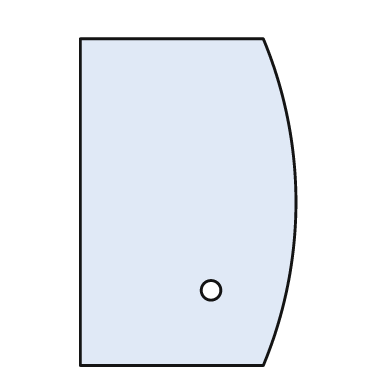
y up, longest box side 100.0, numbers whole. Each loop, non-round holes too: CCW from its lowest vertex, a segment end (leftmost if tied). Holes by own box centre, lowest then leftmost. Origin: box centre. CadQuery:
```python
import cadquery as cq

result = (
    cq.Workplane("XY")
    .moveTo(-33.0, -50.0)
    .lineTo(23.0, -50.0)
    .threePointArc((33.0, 0.0), (23.0, 50.0))
    .lineTo(-33.0, 50.0)
    .close()
    .moveTo(7.0, -27.0)
    .circle(3.0)
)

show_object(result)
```